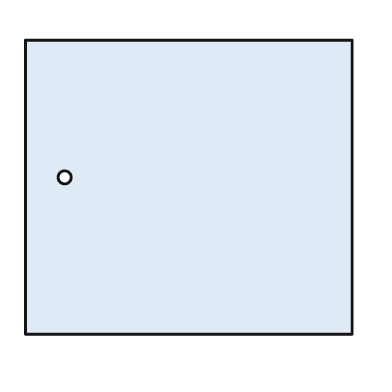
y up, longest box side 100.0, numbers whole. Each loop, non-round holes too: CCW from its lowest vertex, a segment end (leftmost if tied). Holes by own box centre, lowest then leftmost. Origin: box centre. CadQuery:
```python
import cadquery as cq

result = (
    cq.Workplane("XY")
    .moveTo(-50.0, -45.0)
    .lineTo(50.0, -45.0)
    .lineTo(50.0, 45.0)
    .lineTo(-50.0, 45.0)
    .close()
    .moveTo(-38.0, 3.0)
    .circle(2.0)
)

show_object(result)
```